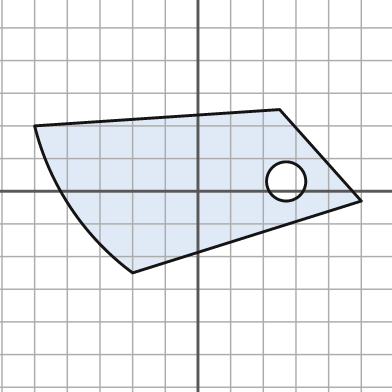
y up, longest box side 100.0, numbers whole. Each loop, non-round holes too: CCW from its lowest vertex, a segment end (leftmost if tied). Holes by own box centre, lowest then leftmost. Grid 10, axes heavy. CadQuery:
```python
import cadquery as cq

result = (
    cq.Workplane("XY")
    .moveTo(-20.0, -25.0)
    .lineTo(50.0, -3.0)
    .lineTo(25.0, 25.0)
    .lineTo(-50.0, 20.0)
    .threePointArc((-39.0, -5.0), (-20.0, -25.0))
    .close()
    .moveTo(27.0, 3.0)
    .circle(6.0)
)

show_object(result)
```